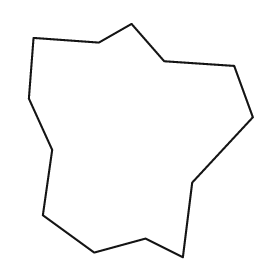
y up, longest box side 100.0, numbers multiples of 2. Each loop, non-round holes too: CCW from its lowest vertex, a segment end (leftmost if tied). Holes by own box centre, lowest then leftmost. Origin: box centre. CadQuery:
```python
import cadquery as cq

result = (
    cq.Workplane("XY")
    .moveTo(18.0, -50.0)
    .lineTo(22.0, -18.0)
    .lineTo(48.0, 10.0)
    .lineTo(40.0, 32.0)
    .lineTo(10.0, 34.0)
    .lineTo(-4.0, 50.0)
    .lineTo(-18.0, 42.0)
    .lineTo(-46.0, 44.0)
    .lineTo(-48.0, 18.0)
    .lineTo(-38.0, -4.0)
    .lineTo(-42.0, -32.0)
    .lineTo(-20.0, -48.0)
    .lineTo(2.0, -42.0)
    .close()
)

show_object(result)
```